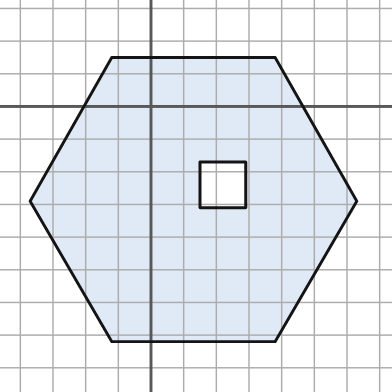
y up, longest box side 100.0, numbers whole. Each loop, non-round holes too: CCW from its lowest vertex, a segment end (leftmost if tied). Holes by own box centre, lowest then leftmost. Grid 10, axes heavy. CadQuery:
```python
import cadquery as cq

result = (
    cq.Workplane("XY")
    .moveTo(-12.0, -72.0)
    .lineTo(38.0, -72.0)
    .lineTo(63.0, -29.0)
    .lineTo(38.0, 15.0)
    .lineTo(-12.0, 15.0)
    .lineTo(-37.0, -29.0)
    .close()
    .moveTo(15.0, -31.0)
    .lineTo(29.0, -31.0)
    .lineTo(29.0, -17.0)
    .lineTo(15.0, -17.0)
    .close()
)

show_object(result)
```